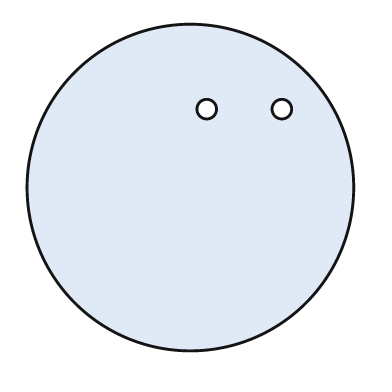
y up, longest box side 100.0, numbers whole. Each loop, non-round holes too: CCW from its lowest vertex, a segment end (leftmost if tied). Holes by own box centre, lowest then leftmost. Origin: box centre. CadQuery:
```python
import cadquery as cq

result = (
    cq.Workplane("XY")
    .moveTo(0.0, 0.0)
    .circle(50.0)
    .moveTo(5.0, 24.0)
    .circle(3.0)
    .moveTo(28.0, 24.0)
    .circle(3.0)
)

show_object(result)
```